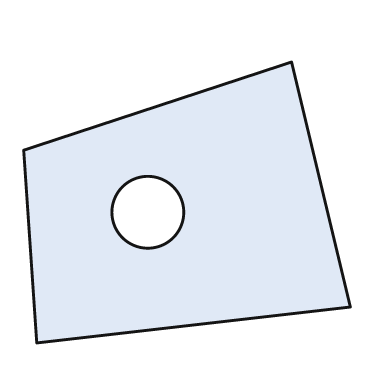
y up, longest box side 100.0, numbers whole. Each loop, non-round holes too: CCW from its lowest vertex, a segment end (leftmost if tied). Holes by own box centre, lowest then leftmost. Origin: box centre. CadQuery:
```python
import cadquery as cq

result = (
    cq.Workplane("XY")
    .moveTo(-46.0, -43.0)
    .lineTo(50.0, -32.0)
    .lineTo(32.0, 43.0)
    .lineTo(-50.0, 16.0)
    .close()
    .moveTo(-12.0, -3.0)
    .circle(11.0)
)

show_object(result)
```